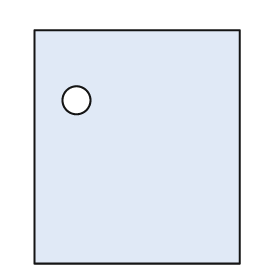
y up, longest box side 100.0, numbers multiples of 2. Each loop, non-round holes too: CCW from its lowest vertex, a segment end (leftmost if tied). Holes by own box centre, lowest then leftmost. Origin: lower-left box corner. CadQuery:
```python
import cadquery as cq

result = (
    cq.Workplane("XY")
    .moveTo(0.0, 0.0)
    .lineTo(88.0, 0.0)
    .lineTo(88.0, 100.0)
    .lineTo(0.0, 100.0)
    .close()
    .moveTo(18.0, 70.0)
    .circle(6.0)
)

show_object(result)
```